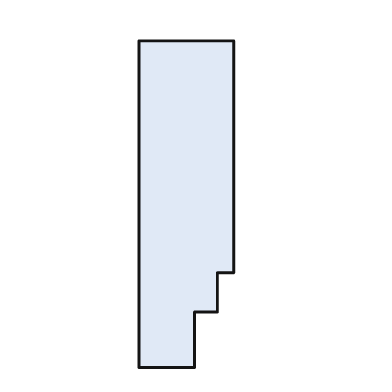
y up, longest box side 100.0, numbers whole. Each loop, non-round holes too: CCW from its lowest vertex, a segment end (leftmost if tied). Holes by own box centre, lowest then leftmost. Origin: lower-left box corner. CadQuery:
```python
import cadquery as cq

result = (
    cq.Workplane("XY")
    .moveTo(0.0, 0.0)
    .lineTo(17.0, 0.0)
    .lineTo(17.0, 17.0)
    .lineTo(24.0, 17.0)
    .lineTo(24.0, 29.0)
    .lineTo(29.0, 29.0)
    .lineTo(29.0, 100.0)
    .lineTo(0.0, 100.0)
    .close()
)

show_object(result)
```